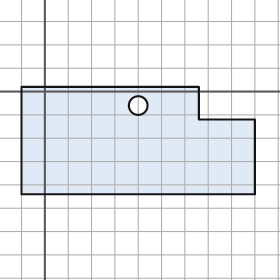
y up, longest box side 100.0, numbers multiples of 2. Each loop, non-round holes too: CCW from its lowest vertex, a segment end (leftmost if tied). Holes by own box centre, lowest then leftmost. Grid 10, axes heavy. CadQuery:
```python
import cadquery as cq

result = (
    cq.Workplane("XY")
    .moveTo(-10.0, -44.0)
    .lineTo(90.0, -44.0)
    .lineTo(90.0, -12.0)
    .lineTo(66.0, -12.0)
    .lineTo(66.0, 2.0)
    .lineTo(-10.0, 2.0)
    .close()
    .moveTo(40.0, -6.0)
    .circle(4.0)
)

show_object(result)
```